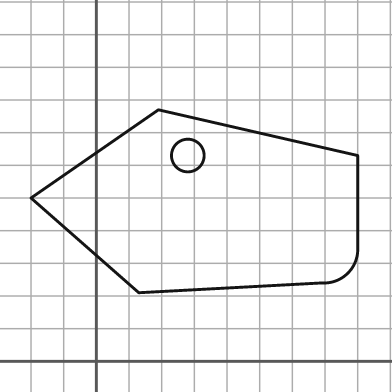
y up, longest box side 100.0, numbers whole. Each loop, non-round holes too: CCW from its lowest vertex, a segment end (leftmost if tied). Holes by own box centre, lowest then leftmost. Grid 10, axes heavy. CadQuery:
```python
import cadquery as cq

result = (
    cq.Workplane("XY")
    .moveTo(13.0, 21.0)
    .lineTo(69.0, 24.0)
    .threePointArc((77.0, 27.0), (80.0, 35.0))
    .lineTo(80.0, 63.0)
    .lineTo(19.0, 77.0)
    .lineTo(-20.0, 50.0)
    .close()
    .moveTo(28.0, 63.0)
    .circle(5.0)
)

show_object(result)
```